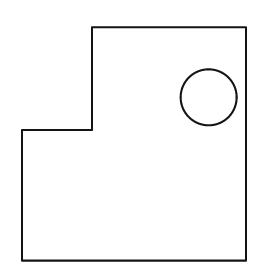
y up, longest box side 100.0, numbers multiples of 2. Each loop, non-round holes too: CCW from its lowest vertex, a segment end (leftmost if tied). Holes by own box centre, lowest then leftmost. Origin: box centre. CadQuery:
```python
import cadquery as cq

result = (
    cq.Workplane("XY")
    .moveTo(-48.0, -50.0)
    .lineTo(48.0, -50.0)
    .lineTo(48.0, 50.0)
    .lineTo(-18.0, 50.0)
    .lineTo(-18.0, 6.0)
    .lineTo(-48.0, 6.0)
    .close()
    .moveTo(32.0, 20.0)
    .circle(12.0)
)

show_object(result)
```